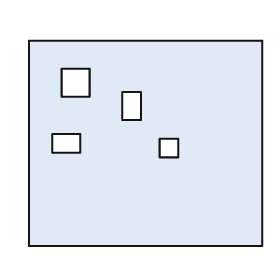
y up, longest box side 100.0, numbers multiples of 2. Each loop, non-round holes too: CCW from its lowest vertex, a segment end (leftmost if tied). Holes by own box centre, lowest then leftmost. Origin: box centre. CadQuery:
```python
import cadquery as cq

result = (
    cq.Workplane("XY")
    .moveTo(-50.0, -44.0)
    .lineTo(50.0, -44.0)
    .lineTo(50.0, 44.0)
    .lineTo(-50.0, 44.0)
    .close()
    .moveTo(6.0, -6.0)
    .lineTo(14.0, -6.0)
    .lineTo(14.0, 2.0)
    .lineTo(6.0, 2.0)
    .close()
    .moveTo(-40.0, -4.0)
    .lineTo(-28.0, -4.0)
    .lineTo(-28.0, 4.0)
    .lineTo(-40.0, 4.0)
    .close()
    .moveTo(-10.0, 10.0)
    .lineTo(-2.0, 10.0)
    .lineTo(-2.0, 22.0)
    .lineTo(-10.0, 22.0)
    .close()
    .moveTo(-36.0, 20.0)
    .lineTo(-24.0, 20.0)
    .lineTo(-24.0, 32.0)
    .lineTo(-36.0, 32.0)
    .close()
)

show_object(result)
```